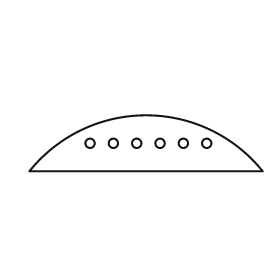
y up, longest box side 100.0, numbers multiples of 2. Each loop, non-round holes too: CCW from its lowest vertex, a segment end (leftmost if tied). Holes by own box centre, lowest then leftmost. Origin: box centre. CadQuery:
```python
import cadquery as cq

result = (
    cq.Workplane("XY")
    .moveTo(-50.0, -12.0)
    .lineTo(50.0, -12.0)
    .threePointArc((0.0, 12.0), (-50.0, -12.0))
    .close()
    .moveTo(-24.0, 0.0)
    .circle(2.0)
    .moveTo(-14.0, 0.0)
    .circle(2.0)
    .moveTo(-4.0, 0.0)
    .circle(2.0)
    .moveTo(6.0, 0.0)
    .circle(2.0)
    .moveTo(16.0, 0.0)
    .circle(2.0)
    .moveTo(26.0, 0.0)
    .circle(2.0)
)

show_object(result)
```